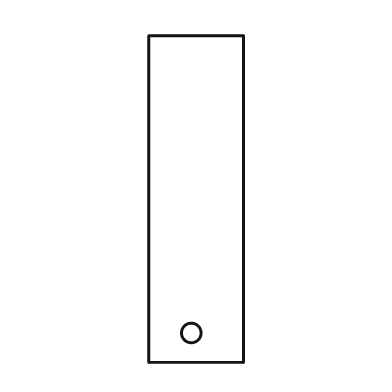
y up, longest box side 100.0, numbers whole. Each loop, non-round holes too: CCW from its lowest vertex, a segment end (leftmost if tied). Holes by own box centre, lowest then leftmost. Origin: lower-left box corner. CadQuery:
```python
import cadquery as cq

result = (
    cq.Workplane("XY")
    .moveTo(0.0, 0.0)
    .lineTo(29.0, 0.0)
    .lineTo(29.0, 100.0)
    .lineTo(0.0, 100.0)
    .close()
    .moveTo(13.0, 9.0)
    .circle(3.0)
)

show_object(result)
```